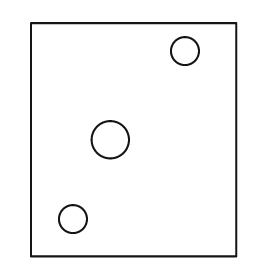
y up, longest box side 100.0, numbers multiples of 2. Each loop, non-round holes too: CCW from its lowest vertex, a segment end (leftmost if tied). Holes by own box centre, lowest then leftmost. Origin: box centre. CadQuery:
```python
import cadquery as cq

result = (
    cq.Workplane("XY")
    .moveTo(-44.0, -50.0)
    .lineTo(44.0, -50.0)
    .lineTo(44.0, 50.0)
    .lineTo(-44.0, 50.0)
    .close()
    .moveTo(-26.0, -34.0)
    .circle(6.0)
    .moveTo(-10.0, 0.0)
    .circle(8.0)
    .moveTo(22.0, 38.0)
    .circle(6.0)
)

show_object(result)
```